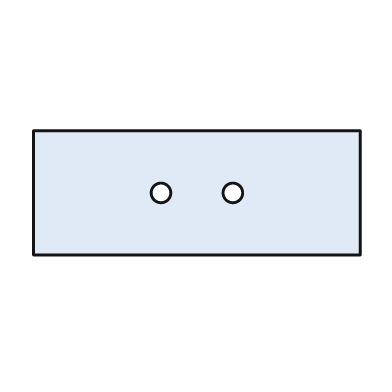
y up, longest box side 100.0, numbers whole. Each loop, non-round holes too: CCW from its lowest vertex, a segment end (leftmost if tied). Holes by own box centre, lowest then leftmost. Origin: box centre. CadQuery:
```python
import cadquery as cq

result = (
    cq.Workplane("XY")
    .moveTo(-50.0, -19.0)
    .lineTo(50.0, -19.0)
    .lineTo(50.0, 19.0)
    .lineTo(-50.0, 19.0)
    .close()
    .moveTo(-11.0, 0.0)
    .circle(3.0)
    .moveTo(11.0, 0.0)
    .circle(3.0)
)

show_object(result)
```